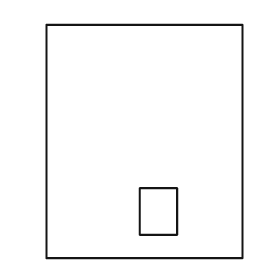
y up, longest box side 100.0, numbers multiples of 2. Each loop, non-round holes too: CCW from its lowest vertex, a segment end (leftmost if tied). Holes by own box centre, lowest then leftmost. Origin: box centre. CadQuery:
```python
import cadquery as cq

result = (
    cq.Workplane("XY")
    .moveTo(-42.0, -50.0)
    .lineTo(42.0, -50.0)
    .lineTo(42.0, 50.0)
    .lineTo(-42.0, 50.0)
    .close()
    .moveTo(-2.0, -40.0)
    .lineTo(14.0, -40.0)
    .lineTo(14.0, -20.0)
    .lineTo(-2.0, -20.0)
    .close()
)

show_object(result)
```